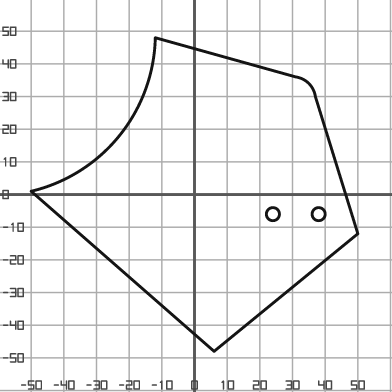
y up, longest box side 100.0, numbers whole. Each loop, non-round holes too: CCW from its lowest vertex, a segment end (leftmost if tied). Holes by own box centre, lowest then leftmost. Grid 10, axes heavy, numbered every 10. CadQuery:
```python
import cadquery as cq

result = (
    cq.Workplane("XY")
    .moveTo(6.0, -48.0)
    .lineTo(50.0, -12.0)
    .lineTo(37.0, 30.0)
    .threePointArc((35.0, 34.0), (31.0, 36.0))
    .lineTo(-12.0, 48.0)
    .threePointArc((-23.0, 18.0), (-50.0, 1.0))
    .close()
    .moveTo(24.0, -6.0)
    .circle(2.0)
    .moveTo(38.0, -6.0)
    .circle(2.0)
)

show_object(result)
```